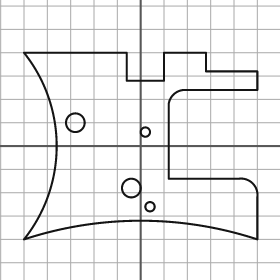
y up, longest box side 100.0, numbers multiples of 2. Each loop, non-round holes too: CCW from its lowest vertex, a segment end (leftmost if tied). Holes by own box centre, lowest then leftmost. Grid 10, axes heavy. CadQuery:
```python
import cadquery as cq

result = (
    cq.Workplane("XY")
    .moveTo(-50.0, -40.0)
    .threePointArc((0.0, -32.0), (50.0, -40.0))
    .lineTo(50.0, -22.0)
    .threePointArc((48.0, -16.0), (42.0, -14.0))
    .lineTo(12.0, -14.0)
    .lineTo(12.0, 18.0)
    .threePointArc((14.0, 22.0), (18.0, 24.0))
    .lineTo(50.0, 24.0)
    .lineTo(50.0, 32.0)
    .lineTo(28.0, 32.0)
    .lineTo(28.0, 40.0)
    .lineTo(10.0, 40.0)
    .lineTo(10.0, 28.0)
    .lineTo(-6.0, 28.0)
    .lineTo(-6.0, 40.0)
    .lineTo(-50.0, 40.0)
    .threePointArc((-36.0, 0.0), (-50.0, -40.0))
    .close()
    .moveTo(4.0, -26.0)
    .circle(2.0)
    .moveTo(-4.0, -18.0)
    .circle(4.0)
    .moveTo(2.0, 6.0)
    .circle(2.0)
    .moveTo(-28.0, 10.0)
    .circle(4.0)
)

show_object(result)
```